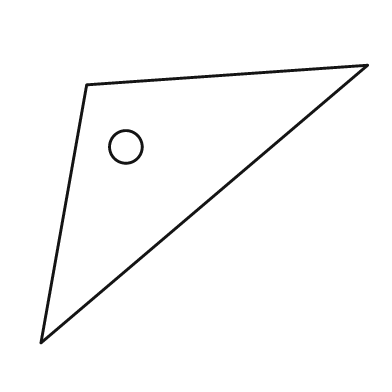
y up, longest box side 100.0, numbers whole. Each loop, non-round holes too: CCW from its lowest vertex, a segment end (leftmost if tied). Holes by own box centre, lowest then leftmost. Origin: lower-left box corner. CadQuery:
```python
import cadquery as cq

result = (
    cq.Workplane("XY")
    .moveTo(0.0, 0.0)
    .lineTo(100.0, 85.0)
    .lineTo(14.0, 79.0)
    .close()
    .moveTo(26.0, 60.0)
    .circle(5.0)
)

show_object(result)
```